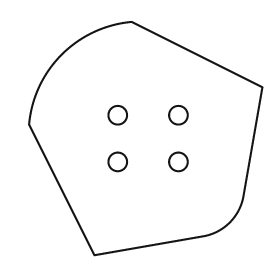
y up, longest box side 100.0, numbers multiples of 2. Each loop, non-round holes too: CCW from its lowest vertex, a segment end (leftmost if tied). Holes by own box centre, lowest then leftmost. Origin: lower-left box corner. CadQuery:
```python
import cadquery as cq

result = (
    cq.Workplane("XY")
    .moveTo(28.0, 0.0)
    .lineTo(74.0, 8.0)
    .threePointArc((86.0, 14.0), (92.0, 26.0))
    .lineTo(100.0, 72.0)
    .lineTo(44.0, 100.0)
    .threePointArc((14.0, 86.0), (0.0, 56.0))
    .close()
    .moveTo(38.0, 40.0)
    .circle(4.0)
    .moveTo(64.0, 40.0)
    .circle(4.0)
    .moveTo(38.0, 60.0)
    .circle(4.0)
    .moveTo(64.0, 60.0)
    .circle(4.0)
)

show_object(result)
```